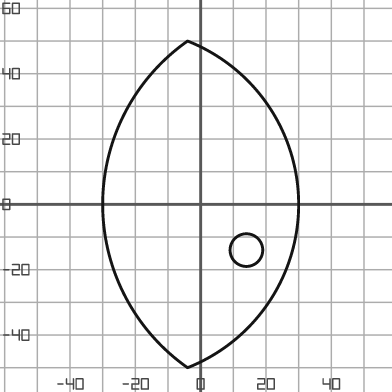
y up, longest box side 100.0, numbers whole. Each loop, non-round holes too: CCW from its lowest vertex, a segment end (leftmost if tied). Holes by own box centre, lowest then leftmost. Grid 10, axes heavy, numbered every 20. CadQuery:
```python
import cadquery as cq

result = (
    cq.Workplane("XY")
    .moveTo(-4.0, -50.0)
    .threePointArc((30.0, 0.0), (-4.0, 50.0))
    .threePointArc((-30.0, 0.0), (-4.0, -50.0))
    .close()
    .moveTo(14.0, -14.0)
    .circle(5.0)
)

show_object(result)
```